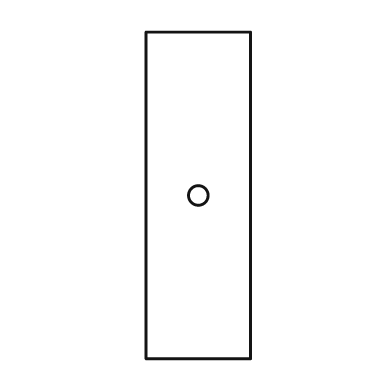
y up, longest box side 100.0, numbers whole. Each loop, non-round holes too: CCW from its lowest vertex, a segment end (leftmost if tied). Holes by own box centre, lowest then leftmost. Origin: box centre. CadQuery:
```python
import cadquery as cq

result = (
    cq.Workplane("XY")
    .moveTo(-16.0, -50.0)
    .lineTo(16.0, -50.0)
    .lineTo(16.0, 50.0)
    .lineTo(-16.0, 50.0)
    .close()
    .moveTo(0.0, 0.0)
    .circle(3.0)
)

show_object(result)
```